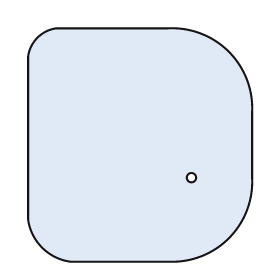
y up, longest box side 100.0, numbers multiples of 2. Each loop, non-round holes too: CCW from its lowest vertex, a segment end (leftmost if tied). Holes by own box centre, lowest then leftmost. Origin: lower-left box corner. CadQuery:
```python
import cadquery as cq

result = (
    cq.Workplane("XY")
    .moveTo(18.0, 0.0)
    .lineTo(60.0, 0.0)
    .threePointArc((86.0, 10.0), (96.0, 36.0))
    .lineTo(96.0, 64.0)
    .threePointArc((86.0, 90.0), (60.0, 100.0))
    .lineTo(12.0, 100.0)
    .threePointArc((4.0, 96.0), (0.0, 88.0))
    .lineTo(0.0, 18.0)
    .threePointArc((6.0, 6.0), (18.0, 0.0))
    .close()
    .moveTo(70.0, 36.0)
    .circle(2.0)
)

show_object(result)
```